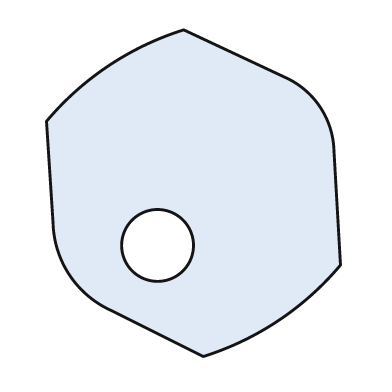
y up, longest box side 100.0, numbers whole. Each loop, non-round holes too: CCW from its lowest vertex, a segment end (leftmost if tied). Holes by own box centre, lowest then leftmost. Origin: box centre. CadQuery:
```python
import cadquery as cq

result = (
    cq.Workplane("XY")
    .moveTo(3.0, -50.0)
    .threePointArc((26.0, -39.0), (45.0, -22.0))
    .lineTo(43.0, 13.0)
    .threePointArc((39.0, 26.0), (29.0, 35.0))
    .lineTo(-3.0, 50.0)
    .threePointArc((-26.0, 39.0), (-45.0, 22.0))
    .lineTo(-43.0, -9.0)
    .threePointArc((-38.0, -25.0), (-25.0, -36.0))
    .close()
    .moveTo(-11.0, -16.0)
    .circle(11.0)
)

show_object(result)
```